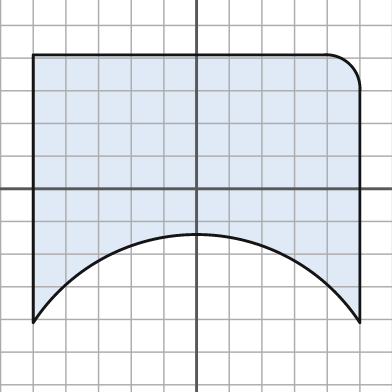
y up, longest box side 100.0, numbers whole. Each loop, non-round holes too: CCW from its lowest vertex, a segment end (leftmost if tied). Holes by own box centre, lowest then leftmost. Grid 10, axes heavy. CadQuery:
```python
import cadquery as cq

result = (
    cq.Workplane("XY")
    .moveTo(-50.0, -41.0)
    .threePointArc((0.0, -14.0), (50.0, -41.0))
    .lineTo(50.0, 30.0)
    .threePointArc((47.0, 38.0), (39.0, 41.0))
    .lineTo(-50.0, 41.0)
    .close()
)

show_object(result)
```